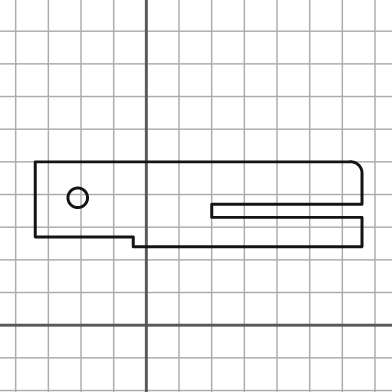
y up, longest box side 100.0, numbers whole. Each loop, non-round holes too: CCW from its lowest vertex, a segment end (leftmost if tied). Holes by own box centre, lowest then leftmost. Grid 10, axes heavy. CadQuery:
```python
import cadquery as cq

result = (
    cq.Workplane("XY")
    .moveTo(-4.0, 24.0)
    .lineTo(66.0, 24.0)
    .lineTo(66.0, 33.0)
    .lineTo(20.0, 33.0)
    .lineTo(20.0, 37.0)
    .lineTo(66.0, 37.0)
    .lineTo(66.0, 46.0)
    .threePointArc((65.0, 49.0), (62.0, 50.0))
    .lineTo(-34.0, 50.0)
    .lineTo(-34.0, 27.0)
    .lineTo(-4.0, 27.0)
    .close()
    .moveTo(-21.0, 39.0)
    .circle(3.0)
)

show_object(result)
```